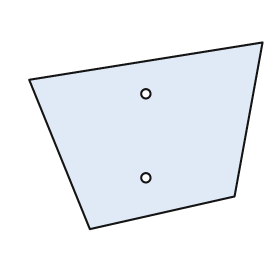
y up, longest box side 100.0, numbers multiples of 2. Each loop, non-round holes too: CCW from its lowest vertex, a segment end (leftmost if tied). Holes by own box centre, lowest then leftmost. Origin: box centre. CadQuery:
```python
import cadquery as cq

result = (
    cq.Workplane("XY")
    .moveTo(-24.0, -40.0)
    .lineTo(38.0, -26.0)
    .lineTo(50.0, 40.0)
    .lineTo(-50.0, 24.0)
    .close()
    .moveTo(0.0, -18.0)
    .circle(2.0)
    .moveTo(0.0, 18.0)
    .circle(2.0)
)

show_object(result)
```